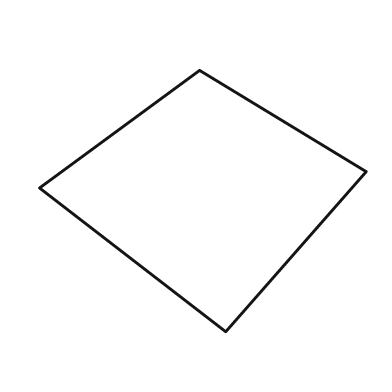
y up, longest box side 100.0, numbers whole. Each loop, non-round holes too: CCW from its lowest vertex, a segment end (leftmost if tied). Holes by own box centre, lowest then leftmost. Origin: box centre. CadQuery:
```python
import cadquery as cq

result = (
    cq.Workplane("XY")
    .moveTo(7.0, -40.0)
    .lineTo(50.0, 9.0)
    .lineTo(-1.0, 40.0)
    .lineTo(-50.0, 4.0)
    .close()
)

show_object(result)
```